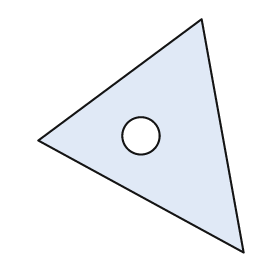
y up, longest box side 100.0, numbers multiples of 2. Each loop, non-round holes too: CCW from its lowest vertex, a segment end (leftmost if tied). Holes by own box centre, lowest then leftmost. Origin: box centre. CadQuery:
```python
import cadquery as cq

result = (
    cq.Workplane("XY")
    .moveTo(44.0, -50.0)
    .lineTo(26.0, 50.0)
    .lineTo(-44.0, -2.0)
    .close()
    .moveTo(0.0, 0.0)
    .circle(8.0)
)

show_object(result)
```